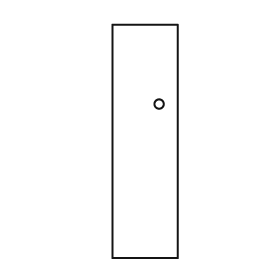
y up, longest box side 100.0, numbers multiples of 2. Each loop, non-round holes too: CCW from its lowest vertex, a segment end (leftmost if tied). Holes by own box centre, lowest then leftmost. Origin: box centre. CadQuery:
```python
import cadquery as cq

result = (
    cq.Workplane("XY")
    .moveTo(-14.0, -50.0)
    .lineTo(14.0, -50.0)
    .lineTo(14.0, 50.0)
    .lineTo(-14.0, 50.0)
    .close()
    .moveTo(6.0, 16.0)
    .circle(2.0)
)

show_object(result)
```